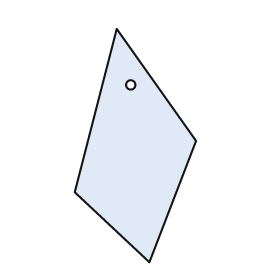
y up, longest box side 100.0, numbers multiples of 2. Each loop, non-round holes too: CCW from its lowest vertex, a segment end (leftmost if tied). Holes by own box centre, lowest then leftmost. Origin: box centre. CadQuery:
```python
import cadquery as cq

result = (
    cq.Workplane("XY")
    .moveTo(6.0, -50.0)
    .lineTo(26.0, 2.0)
    .lineTo(-8.0, 50.0)
    .lineTo(-26.0, -20.0)
    .close()
    .moveTo(-2.0, 26.0)
    .circle(2.0)
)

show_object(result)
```